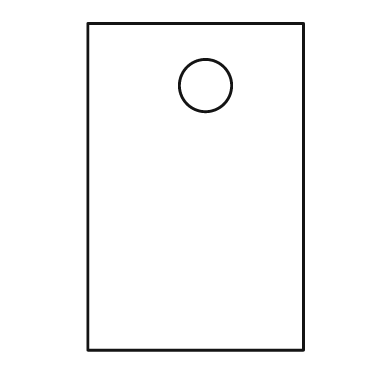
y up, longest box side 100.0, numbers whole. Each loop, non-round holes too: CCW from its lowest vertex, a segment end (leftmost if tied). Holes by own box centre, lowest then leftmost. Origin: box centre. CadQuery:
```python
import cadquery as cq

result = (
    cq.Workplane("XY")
    .moveTo(-33.0, -50.0)
    .lineTo(33.0, -50.0)
    .lineTo(33.0, 50.0)
    .lineTo(-33.0, 50.0)
    .close()
    .moveTo(3.0, 31.0)
    .circle(8.0)
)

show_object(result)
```